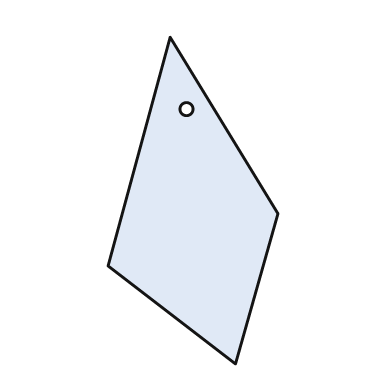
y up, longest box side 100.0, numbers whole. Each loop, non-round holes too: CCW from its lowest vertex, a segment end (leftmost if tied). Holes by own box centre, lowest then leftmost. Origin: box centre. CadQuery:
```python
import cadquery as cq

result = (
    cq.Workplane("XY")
    .moveTo(13.0, -50.0)
    .lineTo(26.0, -4.0)
    .lineTo(-7.0, 50.0)
    .lineTo(-26.0, -20.0)
    .close()
    .moveTo(-2.0, 28.0)
    .circle(2.0)
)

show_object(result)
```